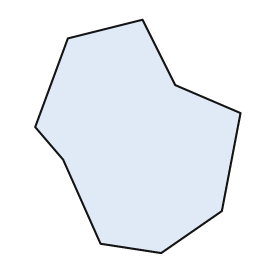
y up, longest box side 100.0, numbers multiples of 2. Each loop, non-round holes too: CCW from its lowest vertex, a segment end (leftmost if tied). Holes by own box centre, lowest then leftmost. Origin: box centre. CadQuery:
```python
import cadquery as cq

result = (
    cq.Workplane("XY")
    .moveTo(10.0, -50.0)
    .lineTo(36.0, -32.0)
    .lineTo(44.0, 10.0)
    .lineTo(16.0, 22.0)
    .lineTo(2.0, 50.0)
    .lineTo(-30.0, 42.0)
    .lineTo(-44.0, 4.0)
    .lineTo(-32.0, -10.0)
    .lineTo(-16.0, -46.0)
    .close()
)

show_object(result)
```